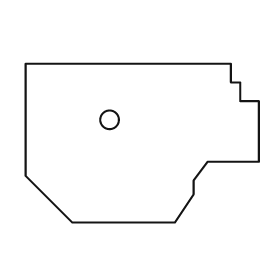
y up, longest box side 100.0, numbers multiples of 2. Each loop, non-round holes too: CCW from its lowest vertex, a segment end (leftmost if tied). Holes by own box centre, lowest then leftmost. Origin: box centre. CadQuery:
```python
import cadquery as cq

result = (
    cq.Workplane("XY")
    .moveTo(-30.0, -34.0)
    .lineTo(14.0, -34.0)
    .lineTo(22.0, -22.0)
    .lineTo(22.0, -16.0)
    .lineTo(28.0, -8.0)
    .lineTo(50.0, -8.0)
    .lineTo(50.0, 18.0)
    .lineTo(42.0, 18.0)
    .lineTo(42.0, 26.0)
    .lineTo(38.0, 26.0)
    .lineTo(38.0, 34.0)
    .lineTo(-50.0, 34.0)
    .lineTo(-50.0, -14.0)
    .close()
    .moveTo(-14.0, 10.0)
    .circle(4.0)
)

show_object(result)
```